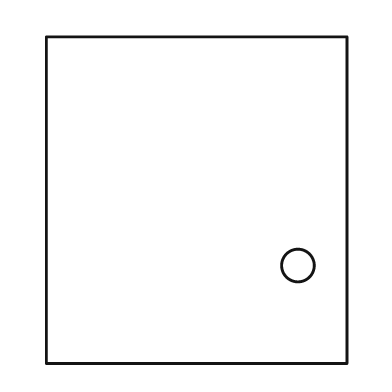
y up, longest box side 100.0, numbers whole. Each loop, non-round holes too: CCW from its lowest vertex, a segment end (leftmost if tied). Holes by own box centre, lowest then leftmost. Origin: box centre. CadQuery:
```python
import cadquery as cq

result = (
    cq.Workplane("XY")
    .moveTo(-46.0, -50.0)
    .lineTo(46.0, -50.0)
    .lineTo(46.0, 50.0)
    .lineTo(-46.0, 50.0)
    .close()
    .moveTo(31.0, -20.0)
    .circle(5.0)
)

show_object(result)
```